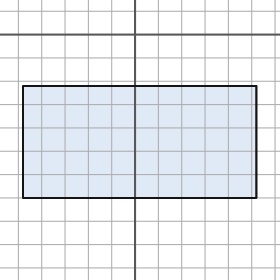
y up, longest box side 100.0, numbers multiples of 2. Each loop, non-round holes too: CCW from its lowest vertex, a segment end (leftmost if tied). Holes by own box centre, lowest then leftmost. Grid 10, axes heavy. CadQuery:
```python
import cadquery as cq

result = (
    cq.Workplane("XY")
    .moveTo(-48.0, -70.0)
    .lineTo(52.0, -70.0)
    .lineTo(52.0, -22.0)
    .lineTo(-48.0, -22.0)
    .close()
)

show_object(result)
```